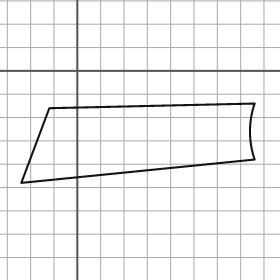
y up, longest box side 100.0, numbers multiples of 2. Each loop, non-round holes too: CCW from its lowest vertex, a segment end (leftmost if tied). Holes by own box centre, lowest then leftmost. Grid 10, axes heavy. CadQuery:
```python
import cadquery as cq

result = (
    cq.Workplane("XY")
    .moveTo(-24.0, -48.0)
    .lineTo(76.0, -38.0)
    .threePointArc((74.0, -26.0), (76.0, -14.0))
    .lineTo(-12.0, -16.0)
    .close()
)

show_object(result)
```